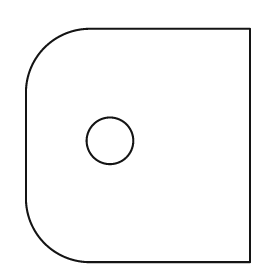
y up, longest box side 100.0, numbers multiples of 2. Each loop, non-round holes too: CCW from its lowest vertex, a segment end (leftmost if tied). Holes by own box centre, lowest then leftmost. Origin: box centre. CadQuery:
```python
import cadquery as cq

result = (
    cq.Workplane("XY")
    .moveTo(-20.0, -50.0)
    .lineTo(48.0, -50.0)
    .lineTo(48.0, 50.0)
    .lineTo(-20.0, 50.0)
    .threePointArc((-40.0, 42.0), (-48.0, 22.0))
    .lineTo(-48.0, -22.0)
    .threePointArc((-40.0, -42.0), (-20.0, -50.0))
    .close()
    .moveTo(-12.0, 2.0)
    .circle(10.0)
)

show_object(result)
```